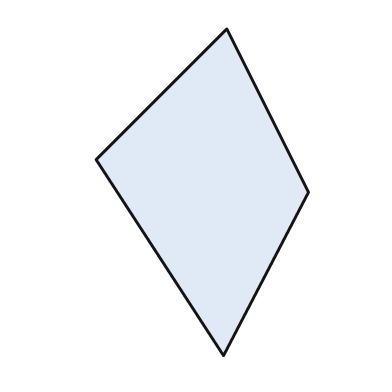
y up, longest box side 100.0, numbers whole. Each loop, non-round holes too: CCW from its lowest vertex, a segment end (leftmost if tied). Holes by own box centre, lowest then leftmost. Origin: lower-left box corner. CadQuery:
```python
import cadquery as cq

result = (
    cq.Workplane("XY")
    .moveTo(39.0, 0.0)
    .lineTo(65.0, 50.0)
    .lineTo(40.0, 100.0)
    .lineTo(0.0, 60.0)
    .close()
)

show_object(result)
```